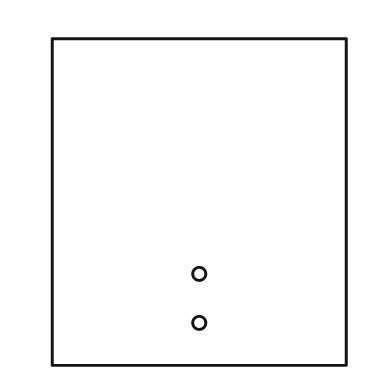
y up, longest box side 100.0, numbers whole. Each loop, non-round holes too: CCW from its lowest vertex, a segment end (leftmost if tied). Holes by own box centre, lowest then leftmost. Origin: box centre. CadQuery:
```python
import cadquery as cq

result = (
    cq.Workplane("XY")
    .moveTo(-45.0, -50.0)
    .lineTo(45.0, -50.0)
    .lineTo(45.0, 50.0)
    .lineTo(-45.0, 50.0)
    .close()
    .moveTo(0.0, -37.0)
    .circle(2.0)
    .moveTo(0.0, -22.0)
    .circle(2.0)
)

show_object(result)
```